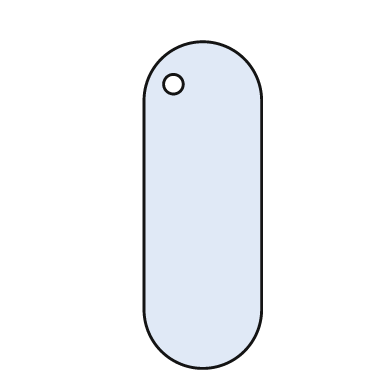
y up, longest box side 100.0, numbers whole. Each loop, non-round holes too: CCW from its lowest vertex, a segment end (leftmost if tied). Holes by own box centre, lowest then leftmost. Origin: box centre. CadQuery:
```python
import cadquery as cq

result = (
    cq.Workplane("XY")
    .moveTo(-18.0, -32.0)
    .threePointArc((0.0, -50.0), (18.0, -32.0))
    .lineTo(18.0, 32.0)
    .threePointArc((0.0, 50.0), (-18.0, 32.0))
    .close()
    .moveTo(-9.0, 37.0)
    .circle(3.0)
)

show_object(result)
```